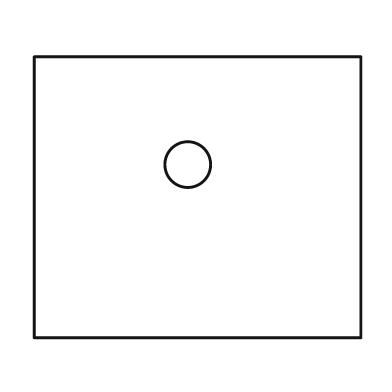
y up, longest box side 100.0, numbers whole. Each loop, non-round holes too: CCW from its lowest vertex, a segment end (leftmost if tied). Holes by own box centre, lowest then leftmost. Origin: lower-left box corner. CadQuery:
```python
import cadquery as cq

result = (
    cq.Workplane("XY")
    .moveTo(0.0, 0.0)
    .lineTo(100.0, 0.0)
    .lineTo(100.0, 86.0)
    .lineTo(0.0, 86.0)
    .close()
    .moveTo(47.0, 53.0)
    .circle(7.0)
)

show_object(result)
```